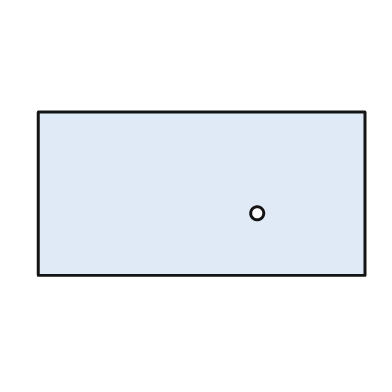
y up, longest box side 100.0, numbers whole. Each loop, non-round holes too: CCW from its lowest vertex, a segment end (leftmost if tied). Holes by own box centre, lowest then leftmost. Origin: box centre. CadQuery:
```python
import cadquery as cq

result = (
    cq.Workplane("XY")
    .moveTo(-50.0, -25.0)
    .lineTo(50.0, -25.0)
    .lineTo(50.0, 25.0)
    .lineTo(-50.0, 25.0)
    .close()
    .moveTo(17.0, -6.0)
    .circle(2.0)
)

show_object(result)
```